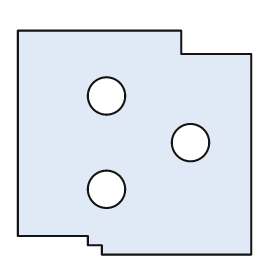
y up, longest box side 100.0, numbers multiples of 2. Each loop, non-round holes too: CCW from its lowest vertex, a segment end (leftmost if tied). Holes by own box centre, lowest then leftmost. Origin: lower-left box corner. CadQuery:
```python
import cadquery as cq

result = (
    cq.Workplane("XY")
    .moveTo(36.0, 0.0)
    .lineTo(100.0, 0.0)
    .lineTo(100.0, 86.0)
    .lineTo(70.0, 86.0)
    .lineTo(70.0, 96.0)
    .lineTo(0.0, 96.0)
    .lineTo(0.0, 8.0)
    .lineTo(30.0, 8.0)
    .lineTo(30.0, 4.0)
    .lineTo(36.0, 4.0)
    .close()
    .moveTo(38.0, 28.0)
    .circle(8.0)
    .moveTo(74.0, 48.0)
    .circle(8.0)
    .moveTo(38.0, 68.0)
    .circle(8.0)
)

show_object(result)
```